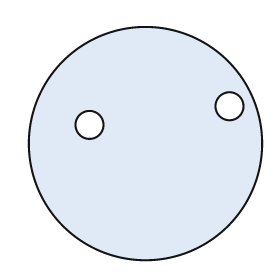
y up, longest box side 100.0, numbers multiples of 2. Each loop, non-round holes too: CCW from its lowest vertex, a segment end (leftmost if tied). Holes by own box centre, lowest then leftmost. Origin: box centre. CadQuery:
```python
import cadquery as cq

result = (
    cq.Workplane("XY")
    .moveTo(0.0, 0.0)
    .circle(50.0)
    .moveTo(-24.0, 8.0)
    .circle(6.0)
    .moveTo(36.0, 16.0)
    .circle(6.0)
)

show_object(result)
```